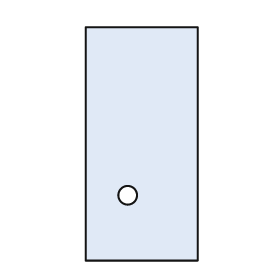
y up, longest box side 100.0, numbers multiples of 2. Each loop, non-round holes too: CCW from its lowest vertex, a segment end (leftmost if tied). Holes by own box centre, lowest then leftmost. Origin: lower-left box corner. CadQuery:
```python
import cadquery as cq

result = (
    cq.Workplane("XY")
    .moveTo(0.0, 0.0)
    .lineTo(48.0, 0.0)
    .lineTo(48.0, 100.0)
    .lineTo(0.0, 100.0)
    .close()
    .moveTo(18.0, 28.0)
    .circle(4.0)
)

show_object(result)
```